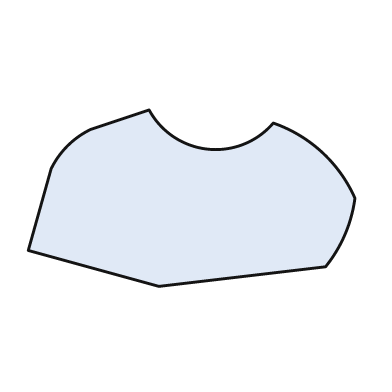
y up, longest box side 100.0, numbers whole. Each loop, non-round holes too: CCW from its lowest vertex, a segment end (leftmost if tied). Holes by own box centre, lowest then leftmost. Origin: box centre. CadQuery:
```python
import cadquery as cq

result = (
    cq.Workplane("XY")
    .moveTo(-10.0, -27.0)
    .lineTo(41.0, -21.0)
    .threePointArc((47.0, -11.0), (50.0, 0.0))
    .threePointArc((40.0, 14.0), (25.0, 23.0))
    .threePointArc((5.0, 15.0), (-13.0, 27.0))
    .lineTo(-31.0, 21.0)
    .threePointArc((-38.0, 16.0), (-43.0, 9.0))
    .lineTo(-50.0, -16.0)
    .close()
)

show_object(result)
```